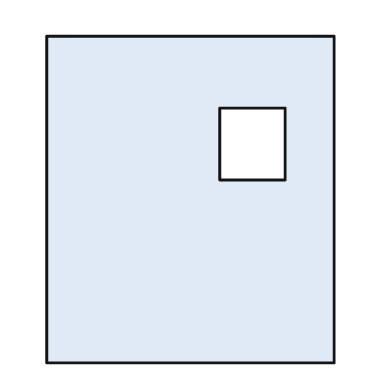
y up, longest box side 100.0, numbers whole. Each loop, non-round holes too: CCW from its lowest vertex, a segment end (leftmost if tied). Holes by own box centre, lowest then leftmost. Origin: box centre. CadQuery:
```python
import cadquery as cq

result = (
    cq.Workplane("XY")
    .moveTo(-44.0, -50.0)
    .lineTo(44.0, -50.0)
    .lineTo(44.0, 50.0)
    .lineTo(-44.0, 50.0)
    .close()
    .moveTo(9.0, 6.0)
    .lineTo(29.0, 6.0)
    .lineTo(29.0, 28.0)
    .lineTo(9.0, 28.0)
    .close()
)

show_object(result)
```